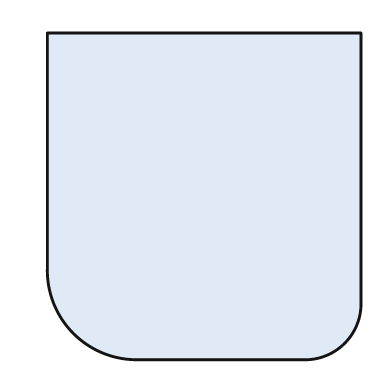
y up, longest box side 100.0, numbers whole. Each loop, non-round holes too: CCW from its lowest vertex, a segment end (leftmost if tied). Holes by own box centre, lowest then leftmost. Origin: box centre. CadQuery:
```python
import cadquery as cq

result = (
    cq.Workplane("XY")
    .moveTo(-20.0, -50.0)
    .lineTo(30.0, -50.0)
    .threePointArc((43.0, -45.0), (48.0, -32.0))
    .lineTo(48.0, 50.0)
    .lineTo(-48.0, 50.0)
    .lineTo(-48.0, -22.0)
    .threePointArc((-40.0, -42.0), (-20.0, -50.0))
    .close()
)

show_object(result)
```